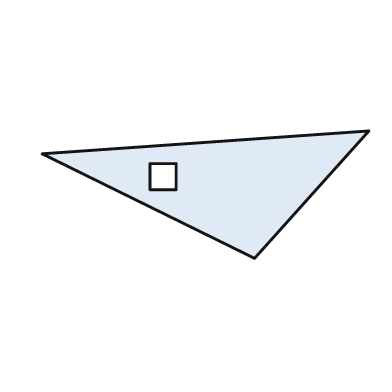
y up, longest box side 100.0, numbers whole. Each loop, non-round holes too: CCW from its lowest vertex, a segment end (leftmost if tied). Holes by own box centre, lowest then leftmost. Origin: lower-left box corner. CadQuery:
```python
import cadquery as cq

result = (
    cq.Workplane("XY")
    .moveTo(65.0, 0.0)
    .lineTo(100.0, 39.0)
    .lineTo(0.0, 32.0)
    .close()
    .moveTo(33.0, 21.0)
    .lineTo(41.0, 21.0)
    .lineTo(41.0, 29.0)
    .lineTo(33.0, 29.0)
    .close()
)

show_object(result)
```